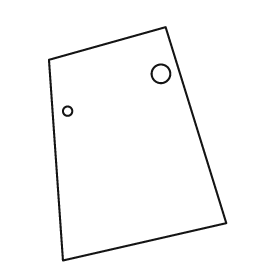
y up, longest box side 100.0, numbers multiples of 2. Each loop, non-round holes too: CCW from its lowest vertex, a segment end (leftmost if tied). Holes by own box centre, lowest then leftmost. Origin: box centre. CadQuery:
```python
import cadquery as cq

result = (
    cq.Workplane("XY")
    .moveTo(-32.0, -50.0)
    .lineTo(38.0, -34.0)
    .lineTo(12.0, 50.0)
    .lineTo(-38.0, 36.0)
    .close()
    .moveTo(-30.0, 14.0)
    .circle(2.0)
    .moveTo(10.0, 30.0)
    .circle(4.0)
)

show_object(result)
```